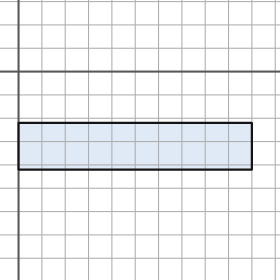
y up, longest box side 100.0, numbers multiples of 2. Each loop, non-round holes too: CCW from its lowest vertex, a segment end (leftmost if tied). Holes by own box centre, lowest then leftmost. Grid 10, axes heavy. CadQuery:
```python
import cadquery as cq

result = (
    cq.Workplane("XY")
    .moveTo(0.0, -42.0)
    .lineTo(100.0, -42.0)
    .lineTo(100.0, -22.0)
    .lineTo(0.0, -22.0)
    .close()
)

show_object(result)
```